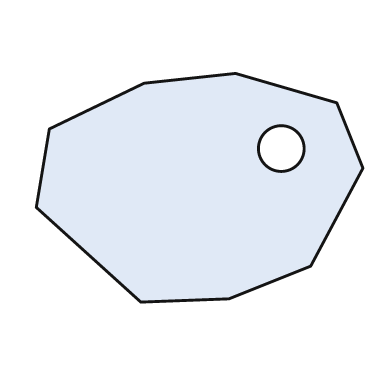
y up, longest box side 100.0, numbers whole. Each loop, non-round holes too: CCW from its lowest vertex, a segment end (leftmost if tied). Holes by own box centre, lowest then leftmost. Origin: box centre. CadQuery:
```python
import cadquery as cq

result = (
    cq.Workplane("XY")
    .moveTo(-18.0, -35.0)
    .lineTo(9.0, -34.0)
    .lineTo(34.0, -24.0)
    .lineTo(50.0, 6.0)
    .lineTo(42.0, 26.0)
    .lineTo(11.0, 35.0)
    .lineTo(-17.0, 32.0)
    .lineTo(-46.0, 18.0)
    .lineTo(-50.0, -6.0)
    .close()
    .moveTo(25.0, 12.0)
    .circle(7.0)
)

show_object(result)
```